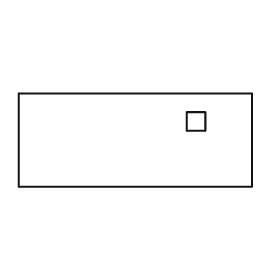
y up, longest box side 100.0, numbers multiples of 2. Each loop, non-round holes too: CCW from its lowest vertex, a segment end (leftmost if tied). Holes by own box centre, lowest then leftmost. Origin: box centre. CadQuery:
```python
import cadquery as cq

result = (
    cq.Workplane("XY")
    .moveTo(-50.0, -20.0)
    .lineTo(50.0, -20.0)
    .lineTo(50.0, 20.0)
    .lineTo(-50.0, 20.0)
    .close()
    .moveTo(22.0, 4.0)
    .lineTo(30.0, 4.0)
    .lineTo(30.0, 12.0)
    .lineTo(22.0, 12.0)
    .close()
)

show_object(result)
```